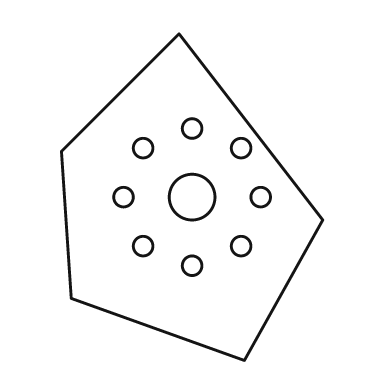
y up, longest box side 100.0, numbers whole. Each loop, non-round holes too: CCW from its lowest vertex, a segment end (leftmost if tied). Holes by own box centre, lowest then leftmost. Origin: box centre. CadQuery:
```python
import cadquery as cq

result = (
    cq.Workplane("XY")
    .moveTo(16.0, -50.0)
    .lineTo(40.0, -7.0)
    .lineTo(-4.0, 50.0)
    .lineTo(-40.0, 14.0)
    .lineTo(-37.0, -31.0)
    .close()
    .moveTo(0.0, -21.0)
    .circle(3.0)
    .moveTo(-15.0, -15.0)
    .circle(3.0)
    .moveTo(15.0, -15.0)
    .circle(3.0)
    .moveTo(-21.0, 0.0)
    .circle(3.0)
    .moveTo(0.0, 0.0)
    .circle(7.0)
    .moveTo(21.0, 0.0)
    .circle(3.0)
    .moveTo(-15.0, 15.0)
    .circle(3.0)
    .moveTo(15.0, 15.0)
    .circle(3.0)
    .moveTo(0.0, 21.0)
    .circle(3.0)
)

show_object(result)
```